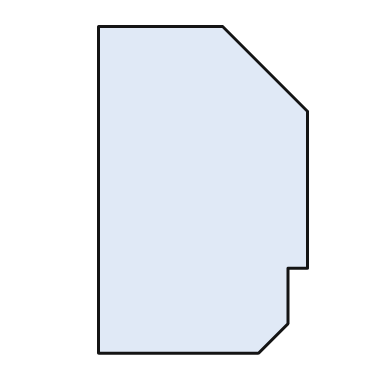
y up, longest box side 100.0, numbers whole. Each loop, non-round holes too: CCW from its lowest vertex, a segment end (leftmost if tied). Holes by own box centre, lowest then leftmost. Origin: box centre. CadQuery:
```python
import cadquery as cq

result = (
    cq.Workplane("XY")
    .moveTo(-32.0, -50.0)
    .lineTo(17.0, -50.0)
    .lineTo(26.0, -41.0)
    .lineTo(26.0, -24.0)
    .lineTo(32.0, -24.0)
    .lineTo(32.0, 24.0)
    .lineTo(6.0, 50.0)
    .lineTo(-32.0, 50.0)
    .close()
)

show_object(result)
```